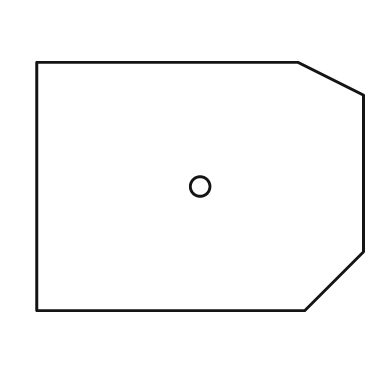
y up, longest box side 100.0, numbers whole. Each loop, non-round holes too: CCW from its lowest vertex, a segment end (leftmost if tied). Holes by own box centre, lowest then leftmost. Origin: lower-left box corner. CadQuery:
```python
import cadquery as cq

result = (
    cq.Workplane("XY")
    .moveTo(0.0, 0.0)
    .lineTo(82.0, 0.0)
    .lineTo(100.0, 18.0)
    .lineTo(100.0, 66.0)
    .lineTo(80.0, 76.0)
    .lineTo(0.0, 76.0)
    .close()
    .moveTo(50.0, 38.0)
    .circle(3.0)
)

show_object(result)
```